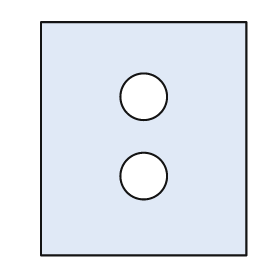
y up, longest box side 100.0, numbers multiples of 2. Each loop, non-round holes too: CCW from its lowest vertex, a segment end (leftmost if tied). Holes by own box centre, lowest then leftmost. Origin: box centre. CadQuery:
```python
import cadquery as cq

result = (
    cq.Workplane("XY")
    .moveTo(-44.0, -50.0)
    .lineTo(44.0, -50.0)
    .lineTo(44.0, 50.0)
    .lineTo(-44.0, 50.0)
    .close()
    .moveTo(0.0, -16.0)
    .circle(10.0)
    .moveTo(0.0, 18.0)
    .circle(10.0)
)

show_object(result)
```